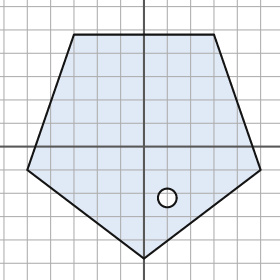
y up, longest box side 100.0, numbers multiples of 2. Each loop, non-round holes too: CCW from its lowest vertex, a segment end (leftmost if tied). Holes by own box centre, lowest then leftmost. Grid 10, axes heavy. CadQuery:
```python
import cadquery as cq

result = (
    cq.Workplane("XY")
    .moveTo(0.0, -48.0)
    .lineTo(50.0, -10.0)
    .lineTo(30.0, 48.0)
    .lineTo(-30.0, 48.0)
    .lineTo(-50.0, -10.0)
    .close()
    .moveTo(10.0, -22.0)
    .circle(4.0)
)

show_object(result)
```